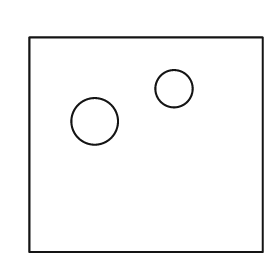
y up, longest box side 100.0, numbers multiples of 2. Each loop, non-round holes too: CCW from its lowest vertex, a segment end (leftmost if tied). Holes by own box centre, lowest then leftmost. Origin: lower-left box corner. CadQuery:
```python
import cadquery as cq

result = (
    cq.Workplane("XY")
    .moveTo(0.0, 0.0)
    .lineTo(100.0, 0.0)
    .lineTo(100.0, 92.0)
    .lineTo(0.0, 92.0)
    .close()
    .moveTo(28.0, 56.0)
    .circle(10.0)
    .moveTo(62.0, 70.0)
    .circle(8.0)
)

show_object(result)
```